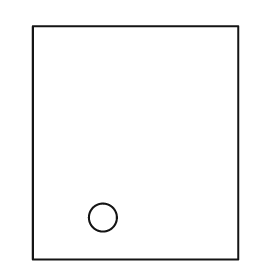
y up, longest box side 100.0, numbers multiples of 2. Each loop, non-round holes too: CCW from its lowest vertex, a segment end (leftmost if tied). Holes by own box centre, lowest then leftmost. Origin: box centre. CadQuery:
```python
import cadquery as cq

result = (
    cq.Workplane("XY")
    .moveTo(-44.0, -50.0)
    .lineTo(44.0, -50.0)
    .lineTo(44.0, 50.0)
    .lineTo(-44.0, 50.0)
    .close()
    .moveTo(-14.0, -32.0)
    .circle(6.0)
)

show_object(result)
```